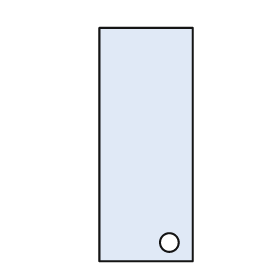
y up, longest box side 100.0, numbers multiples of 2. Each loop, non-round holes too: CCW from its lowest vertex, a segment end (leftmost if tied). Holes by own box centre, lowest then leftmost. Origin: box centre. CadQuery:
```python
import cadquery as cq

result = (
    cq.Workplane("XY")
    .moveTo(-20.0, -50.0)
    .lineTo(20.0, -50.0)
    .lineTo(20.0, 50.0)
    .lineTo(-20.0, 50.0)
    .close()
    .moveTo(10.0, -42.0)
    .circle(4.0)
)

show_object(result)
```